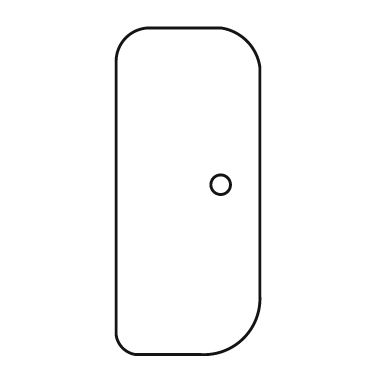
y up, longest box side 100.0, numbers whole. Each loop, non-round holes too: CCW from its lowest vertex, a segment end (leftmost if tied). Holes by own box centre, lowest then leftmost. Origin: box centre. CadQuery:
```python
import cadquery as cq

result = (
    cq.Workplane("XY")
    .moveTo(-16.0, -50.0)
    .lineTo(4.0, -50.0)
    .threePointArc((17.0, -45.0), (22.0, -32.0))
    .lineTo(22.0, 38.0)
    .threePointArc((18.0, 46.0), (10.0, 50.0))
    .lineTo(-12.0, 50.0)
    .threePointArc((-19.0, 47.0), (-22.0, 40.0))
    .lineTo(-22.0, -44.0)
    .threePointArc((-20.0, -48.0), (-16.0, -50.0))
    .close()
    .moveTo(10.0, 2.0)
    .circle(3.0)
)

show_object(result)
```